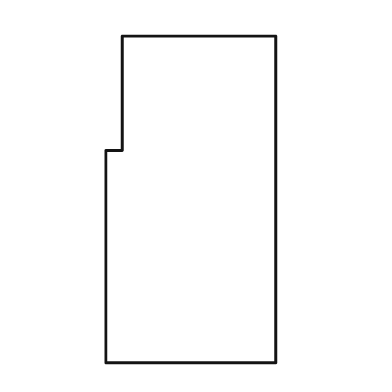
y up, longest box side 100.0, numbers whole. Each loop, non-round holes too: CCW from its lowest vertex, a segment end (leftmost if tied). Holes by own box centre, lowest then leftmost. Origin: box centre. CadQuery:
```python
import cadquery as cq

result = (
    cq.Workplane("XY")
    .moveTo(-26.0, -50.0)
    .lineTo(26.0, -50.0)
    .lineTo(26.0, 50.0)
    .lineTo(-21.0, 50.0)
    .lineTo(-21.0, 15.0)
    .lineTo(-26.0, 15.0)
    .close()
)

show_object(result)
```